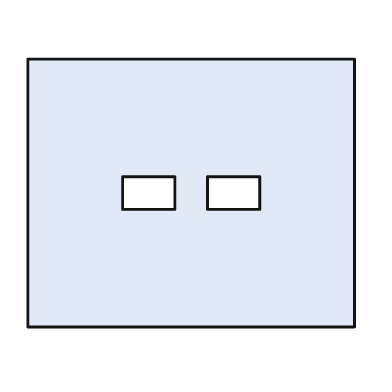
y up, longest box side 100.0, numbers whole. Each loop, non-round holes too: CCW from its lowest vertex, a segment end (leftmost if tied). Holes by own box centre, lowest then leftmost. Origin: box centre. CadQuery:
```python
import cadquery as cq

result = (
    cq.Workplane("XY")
    .moveTo(-50.0, -41.0)
    .lineTo(50.0, -41.0)
    .lineTo(50.0, 41.0)
    .lineTo(-50.0, 41.0)
    .close()
    .moveTo(-21.0, -5.0)
    .lineTo(-5.0, -5.0)
    .lineTo(-5.0, 5.0)
    .lineTo(-21.0, 5.0)
    .close()
    .moveTo(5.0, -5.0)
    .lineTo(21.0, -5.0)
    .lineTo(21.0, 5.0)
    .lineTo(5.0, 5.0)
    .close()
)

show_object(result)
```